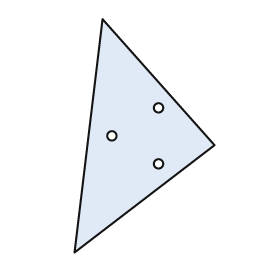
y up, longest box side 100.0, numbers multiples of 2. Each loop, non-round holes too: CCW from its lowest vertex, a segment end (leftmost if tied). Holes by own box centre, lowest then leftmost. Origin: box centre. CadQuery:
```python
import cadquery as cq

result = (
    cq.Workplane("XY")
    .moveTo(-30.0, -50.0)
    .lineTo(30.0, -4.0)
    .lineTo(-18.0, 50.0)
    .close()
    .moveTo(6.0, -12.0)
    .circle(2.0)
    .moveTo(-14.0, 0.0)
    .circle(2.0)
    .moveTo(6.0, 12.0)
    .circle(2.0)
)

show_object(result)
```